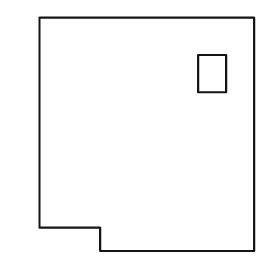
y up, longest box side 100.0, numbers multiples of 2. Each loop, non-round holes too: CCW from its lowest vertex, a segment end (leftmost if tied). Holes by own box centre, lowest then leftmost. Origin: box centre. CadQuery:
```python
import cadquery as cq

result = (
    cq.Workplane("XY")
    .moveTo(-20.0, -50.0)
    .lineTo(46.0, -50.0)
    .lineTo(46.0, 50.0)
    .lineTo(-46.0, 50.0)
    .lineTo(-46.0, -40.0)
    .lineTo(-20.0, -40.0)
    .close()
    .moveTo(22.0, 18.0)
    .lineTo(34.0, 18.0)
    .lineTo(34.0, 34.0)
    .lineTo(22.0, 34.0)
    .close()
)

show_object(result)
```